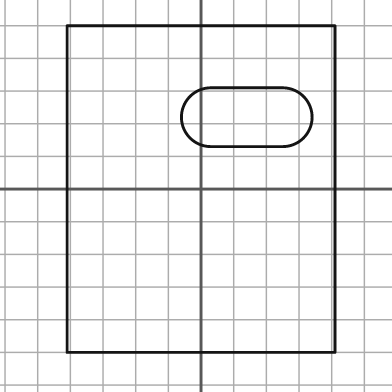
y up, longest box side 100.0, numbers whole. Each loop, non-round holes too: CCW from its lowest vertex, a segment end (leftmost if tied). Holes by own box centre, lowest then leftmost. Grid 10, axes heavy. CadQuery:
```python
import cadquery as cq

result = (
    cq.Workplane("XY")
    .moveTo(-41.0, -50.0)
    .lineTo(41.0, -50.0)
    .lineTo(41.0, 50.0)
    .lineTo(-41.0, 50.0)
    .close()
    .moveTo(3.0, 13.0)
    .lineTo(25.0, 13.0)
    .threePointArc((34.0, 22.0), (25.0, 31.0))
    .lineTo(3.0, 31.0)
    .threePointArc((-6.0, 22.0), (3.0, 13.0))
    .close()
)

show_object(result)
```